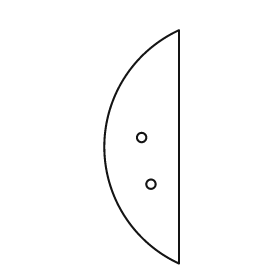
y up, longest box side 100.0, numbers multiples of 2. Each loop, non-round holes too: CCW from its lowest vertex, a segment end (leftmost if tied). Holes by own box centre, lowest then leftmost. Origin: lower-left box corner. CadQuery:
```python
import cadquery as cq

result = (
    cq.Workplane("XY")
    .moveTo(32.0, 0.0)
    .lineTo(32.0, 100.0)
    .threePointArc((0.0, 50.0), (32.0, 0.0))
    .close()
    .moveTo(20.0, 34.0)
    .circle(2.0)
    .moveTo(16.0, 54.0)
    .circle(2.0)
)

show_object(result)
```